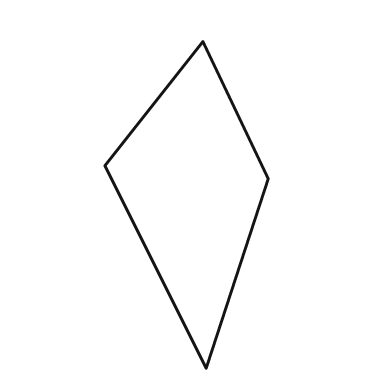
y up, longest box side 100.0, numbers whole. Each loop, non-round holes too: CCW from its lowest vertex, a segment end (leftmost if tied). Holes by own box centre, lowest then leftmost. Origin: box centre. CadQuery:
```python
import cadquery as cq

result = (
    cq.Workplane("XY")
    .moveTo(6.0, -50.0)
    .lineTo(25.0, 8.0)
    .lineTo(5.0, 50.0)
    .lineTo(-25.0, 12.0)
    .close()
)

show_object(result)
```